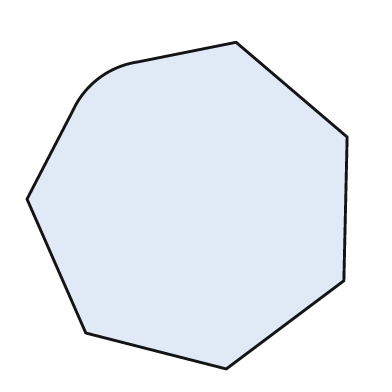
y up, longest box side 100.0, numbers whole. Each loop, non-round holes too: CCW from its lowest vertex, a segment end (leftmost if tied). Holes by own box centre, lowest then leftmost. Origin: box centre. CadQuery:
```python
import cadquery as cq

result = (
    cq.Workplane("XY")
    .moveTo(12.0, -50.0)
    .lineTo(48.0, -23.0)
    .lineTo(49.0, 21.0)
    .lineTo(15.0, 50.0)
    .lineTo(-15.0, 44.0)
    .threePointArc((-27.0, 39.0), (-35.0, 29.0))
    .lineTo(-49.0, 2.0)
    .lineTo(-31.0, -39.0)
    .close()
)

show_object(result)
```